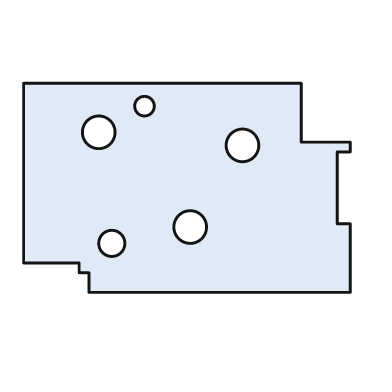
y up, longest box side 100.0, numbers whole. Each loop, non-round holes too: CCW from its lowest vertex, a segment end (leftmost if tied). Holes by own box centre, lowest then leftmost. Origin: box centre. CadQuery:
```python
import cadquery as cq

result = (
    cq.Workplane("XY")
    .moveTo(-30.0, -32.0)
    .lineTo(50.0, -32.0)
    .lineTo(50.0, -11.0)
    .lineTo(46.0, -11.0)
    .lineTo(46.0, 11.0)
    .lineTo(50.0, 11.0)
    .lineTo(50.0, 14.0)
    .lineTo(35.0, 14.0)
    .lineTo(35.0, 32.0)
    .lineTo(-50.0, 32.0)
    .lineTo(-50.0, -23.0)
    .lineTo(-33.0, -23.0)
    .lineTo(-33.0, -26.0)
    .lineTo(-30.0, -26.0)
    .close()
    .moveTo(-23.0, -17.0)
    .circle(4.0)
    .moveTo(1.0, -12.0)
    .circle(5.0)
    .moveTo(17.0, 13.0)
    .circle(5.0)
    .moveTo(-27.0, 17.0)
    .circle(5.0)
    .moveTo(-13.0, 25.0)
    .circle(3.0)
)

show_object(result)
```